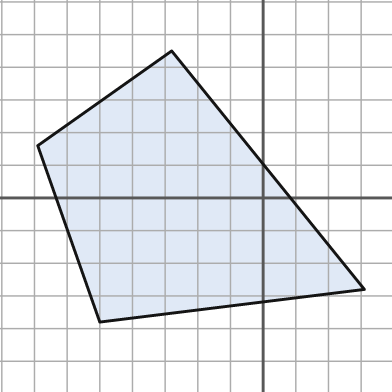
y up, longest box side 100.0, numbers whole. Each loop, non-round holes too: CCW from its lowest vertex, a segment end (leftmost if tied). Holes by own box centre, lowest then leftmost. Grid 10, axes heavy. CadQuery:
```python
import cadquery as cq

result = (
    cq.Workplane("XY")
    .moveTo(-50.0, -38.0)
    .lineTo(31.0, -28.0)
    .lineTo(-28.0, 45.0)
    .lineTo(-69.0, 16.0)
    .close()
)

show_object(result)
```